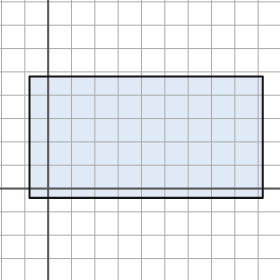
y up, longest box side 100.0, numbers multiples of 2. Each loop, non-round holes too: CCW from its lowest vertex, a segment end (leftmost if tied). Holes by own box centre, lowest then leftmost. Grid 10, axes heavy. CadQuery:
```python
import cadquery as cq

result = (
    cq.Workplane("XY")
    .moveTo(-8.0, -4.0)
    .lineTo(92.0, -4.0)
    .lineTo(92.0, 48.0)
    .lineTo(-8.0, 48.0)
    .close()
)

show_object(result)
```